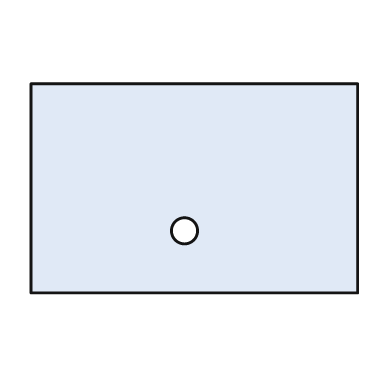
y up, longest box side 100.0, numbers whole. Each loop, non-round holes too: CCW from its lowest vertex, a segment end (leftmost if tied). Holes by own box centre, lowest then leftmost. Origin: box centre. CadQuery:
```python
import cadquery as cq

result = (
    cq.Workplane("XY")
    .moveTo(-50.0, -32.0)
    .lineTo(50.0, -32.0)
    .lineTo(50.0, 32.0)
    .lineTo(-50.0, 32.0)
    .close()
    .moveTo(-3.0, -13.0)
    .circle(4.0)
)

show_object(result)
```